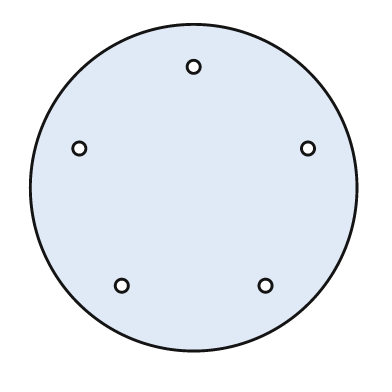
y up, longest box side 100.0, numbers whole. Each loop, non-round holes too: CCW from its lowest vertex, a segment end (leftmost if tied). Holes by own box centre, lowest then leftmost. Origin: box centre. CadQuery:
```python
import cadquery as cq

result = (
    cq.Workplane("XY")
    .moveTo(0.0, 0.0)
    .circle(50.0)
    .moveTo(-22.0, -30.0)
    .circle(2.0)
    .moveTo(22.0, -30.0)
    .circle(2.0)
    .moveTo(-35.0, 12.0)
    .circle(2.0)
    .moveTo(35.0, 12.0)
    .circle(2.0)
    .moveTo(0.0, 37.0)
    .circle(2.0)
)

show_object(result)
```